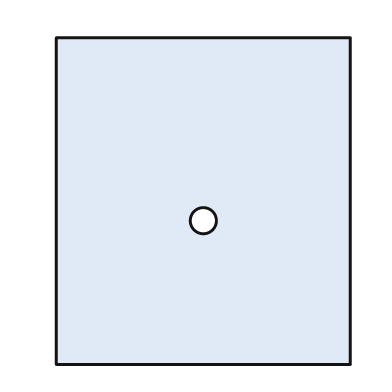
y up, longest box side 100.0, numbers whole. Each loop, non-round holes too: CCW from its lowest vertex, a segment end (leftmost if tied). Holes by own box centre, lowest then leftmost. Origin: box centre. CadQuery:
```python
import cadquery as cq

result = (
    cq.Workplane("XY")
    .moveTo(-45.0, -50.0)
    .lineTo(45.0, -50.0)
    .lineTo(45.0, 50.0)
    .lineTo(-45.0, 50.0)
    .close()
    .moveTo(0.0, -6.0)
    .circle(4.0)
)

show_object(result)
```